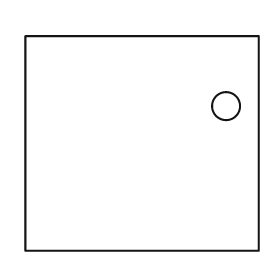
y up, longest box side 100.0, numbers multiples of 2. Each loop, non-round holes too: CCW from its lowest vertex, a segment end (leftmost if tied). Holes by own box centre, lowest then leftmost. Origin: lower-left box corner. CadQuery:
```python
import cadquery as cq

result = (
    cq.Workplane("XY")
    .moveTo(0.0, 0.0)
    .lineTo(100.0, 0.0)
    .lineTo(100.0, 92.0)
    .lineTo(0.0, 92.0)
    .close()
    .moveTo(86.0, 62.0)
    .circle(6.0)
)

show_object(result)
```